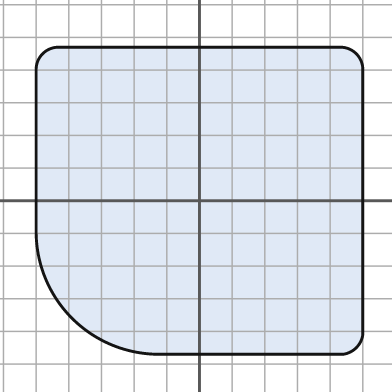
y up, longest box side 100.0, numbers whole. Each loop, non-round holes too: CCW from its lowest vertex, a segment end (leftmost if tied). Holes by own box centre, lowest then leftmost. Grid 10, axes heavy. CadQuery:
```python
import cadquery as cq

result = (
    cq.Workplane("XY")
    .moveTo(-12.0, -47.0)
    .lineTo(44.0, -47.0)
    .threePointArc((48.0, -45.0), (50.0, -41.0))
    .lineTo(50.0, 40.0)
    .threePointArc((48.0, 45.0), (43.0, 47.0))
    .lineTo(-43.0, 47.0)
    .threePointArc((-48.0, 45.0), (-50.0, 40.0))
    .lineTo(-50.0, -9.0)
    .threePointArc((-39.0, -36.0), (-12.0, -47.0))
    .close()
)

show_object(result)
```